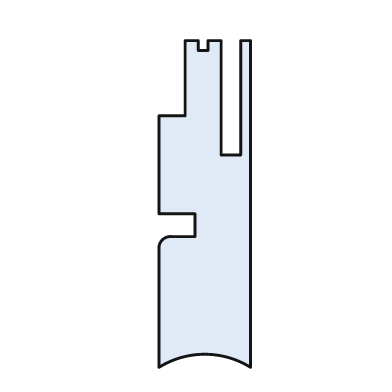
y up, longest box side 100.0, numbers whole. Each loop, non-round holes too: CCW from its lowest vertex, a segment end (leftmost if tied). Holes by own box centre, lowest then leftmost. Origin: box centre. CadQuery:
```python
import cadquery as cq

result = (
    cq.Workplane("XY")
    .moveTo(-14.0, -50.0)
    .threePointArc((0.0, -46.0), (14.0, -50.0))
    .lineTo(14.0, 50.0)
    .lineTo(11.0, 50.0)
    .lineTo(11.0, 15.0)
    .lineTo(5.0, 15.0)
    .lineTo(5.0, 50.0)
    .lineTo(1.0, 50.0)
    .lineTo(1.0, 47.0)
    .lineTo(-2.0, 47.0)
    .lineTo(-2.0, 50.0)
    .lineTo(-6.0, 50.0)
    .lineTo(-6.0, 27.0)
    .lineTo(-14.0, 27.0)
    .lineTo(-14.0, -3.0)
    .lineTo(-3.0, -3.0)
    .lineTo(-3.0, -10.0)
    .lineTo(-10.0, -10.0)
    .threePointArc((-13.0, -11.0), (-14.0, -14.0))
    .close()
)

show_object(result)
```